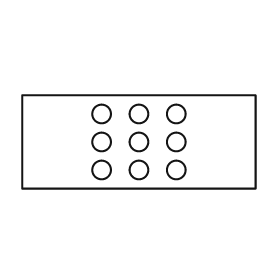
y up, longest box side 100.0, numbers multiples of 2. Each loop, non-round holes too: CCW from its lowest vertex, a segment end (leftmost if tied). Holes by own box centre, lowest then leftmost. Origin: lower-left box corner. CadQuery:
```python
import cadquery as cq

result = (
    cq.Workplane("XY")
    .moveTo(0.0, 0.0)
    .lineTo(100.0, 0.0)
    .lineTo(100.0, 40.0)
    .lineTo(0.0, 40.0)
    .close()
    .moveTo(34.0, 8.0)
    .circle(4.0)
    .moveTo(50.0, 8.0)
    .circle(4.0)
    .moveTo(66.0, 8.0)
    .circle(4.0)
    .moveTo(34.0, 20.0)
    .circle(4.0)
    .moveTo(50.0, 20.0)
    .circle(4.0)
    .moveTo(66.0, 20.0)
    .circle(4.0)
    .moveTo(34.0, 32.0)
    .circle(4.0)
    .moveTo(50.0, 32.0)
    .circle(4.0)
    .moveTo(66.0, 32.0)
    .circle(4.0)
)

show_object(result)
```